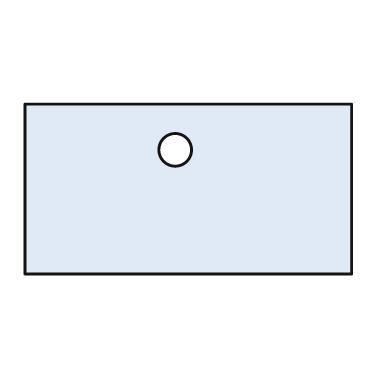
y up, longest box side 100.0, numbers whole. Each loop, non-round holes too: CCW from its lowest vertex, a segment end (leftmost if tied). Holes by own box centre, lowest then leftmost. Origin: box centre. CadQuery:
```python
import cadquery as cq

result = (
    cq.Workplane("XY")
    .moveTo(-50.0, -26.0)
    .lineTo(50.0, -26.0)
    .lineTo(50.0, 26.0)
    .lineTo(-50.0, 26.0)
    .close()
    .moveTo(-4.0, 12.0)
    .circle(5.0)
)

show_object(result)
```